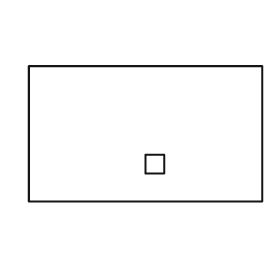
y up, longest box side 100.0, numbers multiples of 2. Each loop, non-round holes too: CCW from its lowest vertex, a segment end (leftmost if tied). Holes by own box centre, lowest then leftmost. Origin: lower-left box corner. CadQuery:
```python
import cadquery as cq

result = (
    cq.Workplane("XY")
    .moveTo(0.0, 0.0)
    .lineTo(100.0, 0.0)
    .lineTo(100.0, 58.0)
    .lineTo(0.0, 58.0)
    .close()
    .moveTo(50.0, 12.0)
    .lineTo(58.0, 12.0)
    .lineTo(58.0, 20.0)
    .lineTo(50.0, 20.0)
    .close()
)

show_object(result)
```